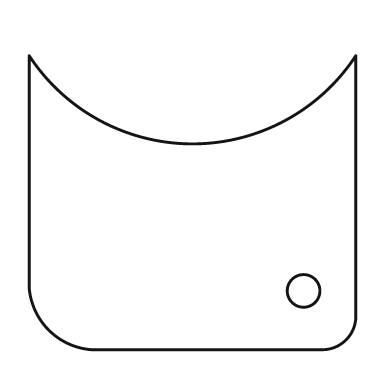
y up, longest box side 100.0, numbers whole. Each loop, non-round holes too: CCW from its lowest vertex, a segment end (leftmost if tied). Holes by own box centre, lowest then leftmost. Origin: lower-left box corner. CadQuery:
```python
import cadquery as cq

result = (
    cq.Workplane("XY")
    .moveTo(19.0, 0.0)
    .lineTo(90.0, 0.0)
    .threePointArc((97.0, 3.0), (100.0, 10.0))
    .lineTo(100.0, 90.0)
    .threePointArc((50.0, 63.0), (0.0, 90.0))
    .lineTo(0.0, 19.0)
    .threePointArc((6.0, 6.0), (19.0, 0.0))
    .close()
    .moveTo(84.0, 18.0)
    .circle(5.0)
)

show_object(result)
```